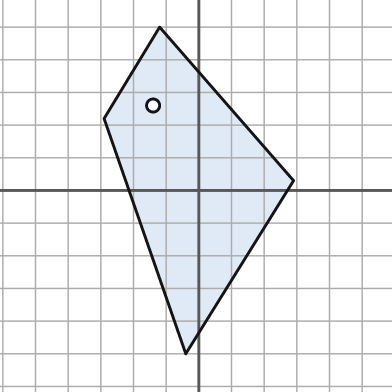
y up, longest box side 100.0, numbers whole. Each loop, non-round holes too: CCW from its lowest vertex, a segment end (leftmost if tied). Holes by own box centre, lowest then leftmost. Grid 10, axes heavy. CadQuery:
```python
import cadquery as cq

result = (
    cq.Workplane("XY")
    .moveTo(-4.0, -50.0)
    .lineTo(29.0, 3.0)
    .lineTo(-12.0, 50.0)
    .lineTo(-29.0, 22.0)
    .close()
    .moveTo(-14.0, 26.0)
    .circle(2.0)
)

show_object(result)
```